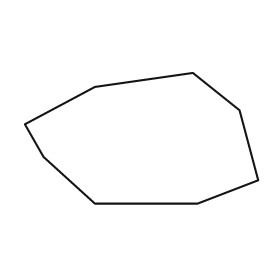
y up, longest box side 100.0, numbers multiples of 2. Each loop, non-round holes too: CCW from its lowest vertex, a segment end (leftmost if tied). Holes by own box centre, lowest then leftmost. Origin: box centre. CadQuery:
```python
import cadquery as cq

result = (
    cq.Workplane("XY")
    .moveTo(-20.0, -28.0)
    .lineTo(24.0, -28.0)
    .lineTo(50.0, -18.0)
    .lineTo(42.0, 12.0)
    .lineTo(22.0, 28.0)
    .lineTo(-20.0, 22.0)
    .lineTo(-50.0, 6.0)
    .lineTo(-42.0, -8.0)
    .close()
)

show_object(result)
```